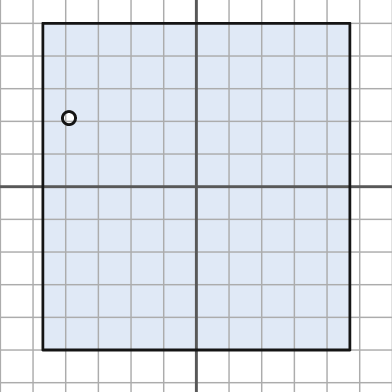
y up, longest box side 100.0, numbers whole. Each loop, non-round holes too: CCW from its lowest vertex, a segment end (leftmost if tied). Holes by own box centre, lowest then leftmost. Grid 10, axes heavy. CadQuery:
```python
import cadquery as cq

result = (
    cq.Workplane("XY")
    .moveTo(-47.0, -50.0)
    .lineTo(47.0, -50.0)
    .lineTo(47.0, 50.0)
    .lineTo(-47.0, 50.0)
    .close()
    .moveTo(-39.0, 21.0)
    .circle(2.0)
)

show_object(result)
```